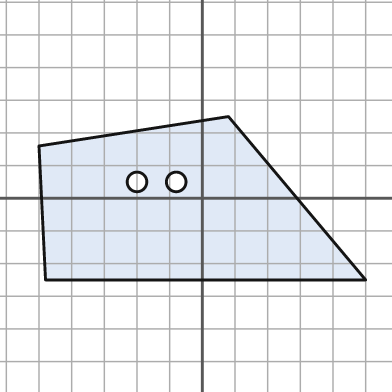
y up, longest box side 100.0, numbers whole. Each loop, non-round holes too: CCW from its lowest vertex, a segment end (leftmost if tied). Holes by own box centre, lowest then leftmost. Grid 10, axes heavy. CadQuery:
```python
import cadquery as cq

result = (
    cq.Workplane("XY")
    .moveTo(-48.0, -25.0)
    .lineTo(50.0, -25.0)
    .lineTo(8.0, 25.0)
    .lineTo(-50.0, 16.0)
    .close()
    .moveTo(-20.0, 5.0)
    .circle(3.0)
    .moveTo(-8.0, 5.0)
    .circle(3.0)
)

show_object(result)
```